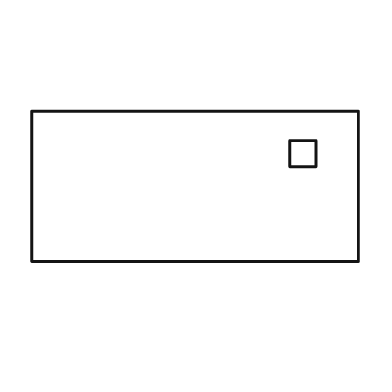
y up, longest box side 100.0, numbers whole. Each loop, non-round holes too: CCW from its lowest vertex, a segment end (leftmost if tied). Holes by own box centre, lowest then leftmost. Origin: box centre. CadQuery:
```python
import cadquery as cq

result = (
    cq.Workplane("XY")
    .moveTo(-50.0, -23.0)
    .lineTo(50.0, -23.0)
    .lineTo(50.0, 23.0)
    .lineTo(-50.0, 23.0)
    .close()
    .moveTo(29.0, 6.0)
    .lineTo(37.0, 6.0)
    .lineTo(37.0, 14.0)
    .lineTo(29.0, 14.0)
    .close()
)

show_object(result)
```